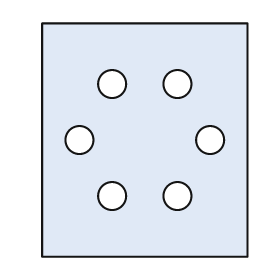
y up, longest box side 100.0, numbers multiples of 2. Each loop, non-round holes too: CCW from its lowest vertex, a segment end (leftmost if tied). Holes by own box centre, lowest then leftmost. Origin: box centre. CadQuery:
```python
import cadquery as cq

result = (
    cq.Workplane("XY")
    .moveTo(-44.0, -50.0)
    .lineTo(44.0, -50.0)
    .lineTo(44.0, 50.0)
    .lineTo(-44.0, 50.0)
    .close()
    .moveTo(-14.0, -24.0)
    .circle(6.0)
    .moveTo(14.0, -24.0)
    .circle(6.0)
    .moveTo(-28.0, 0.0)
    .circle(6.0)
    .moveTo(28.0, 0.0)
    .circle(6.0)
    .moveTo(-14.0, 24.0)
    .circle(6.0)
    .moveTo(14.0, 24.0)
    .circle(6.0)
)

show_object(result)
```